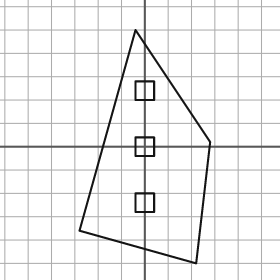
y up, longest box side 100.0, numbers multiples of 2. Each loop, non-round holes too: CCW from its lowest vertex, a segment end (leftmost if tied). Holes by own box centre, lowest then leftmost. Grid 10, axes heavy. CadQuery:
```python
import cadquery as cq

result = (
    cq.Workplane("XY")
    .moveTo(22.0, -50.0)
    .lineTo(28.0, 2.0)
    .lineTo(-4.0, 50.0)
    .lineTo(-28.0, -36.0)
    .close()
    .moveTo(-4.0, -28.0)
    .lineTo(4.0, -28.0)
    .lineTo(4.0, -20.0)
    .lineTo(-4.0, -20.0)
    .close()
    .moveTo(-4.0, -4.0)
    .lineTo(4.0, -4.0)
    .lineTo(4.0, 4.0)
    .lineTo(-4.0, 4.0)
    .close()
    .moveTo(-4.0, 20.0)
    .lineTo(4.0, 20.0)
    .lineTo(4.0, 28.0)
    .lineTo(-4.0, 28.0)
    .close()
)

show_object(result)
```